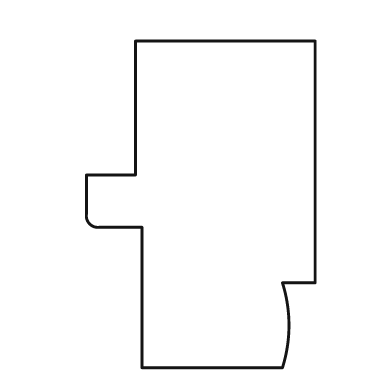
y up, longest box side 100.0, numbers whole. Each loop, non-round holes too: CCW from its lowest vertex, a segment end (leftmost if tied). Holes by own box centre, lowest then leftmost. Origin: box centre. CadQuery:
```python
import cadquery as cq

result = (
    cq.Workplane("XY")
    .moveTo(-18.0, -50.0)
    .lineTo(25.0, -50.0)
    .threePointArc((27.0, -37.0), (25.0, -24.0))
    .lineTo(35.0, -24.0)
    .lineTo(35.0, 50.0)
    .lineTo(-20.0, 50.0)
    .lineTo(-20.0, 9.0)
    .lineTo(-35.0, 9.0)
    .lineTo(-35.0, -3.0)
    .threePointArc((-34.0, -6.0), (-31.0, -7.0))
    .lineTo(-18.0, -7.0)
    .close()
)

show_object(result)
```